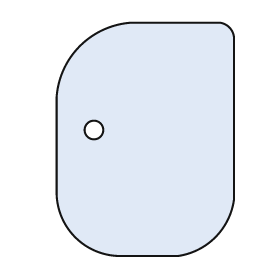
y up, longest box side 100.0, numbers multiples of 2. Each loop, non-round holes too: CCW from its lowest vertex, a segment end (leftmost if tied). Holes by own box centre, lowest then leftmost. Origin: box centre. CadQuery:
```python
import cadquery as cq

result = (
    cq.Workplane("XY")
    .moveTo(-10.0, -50.0)
    .lineTo(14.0, -50.0)
    .threePointArc((30.0, -42.0), (38.0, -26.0))
    .lineTo(38.0, 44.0)
    .threePointArc((36.0, 48.0), (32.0, 50.0))
    .lineTo(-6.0, 50.0)
    .threePointArc((-28.0, 40.0), (-38.0, 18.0))
    .lineTo(-38.0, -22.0)
    .threePointArc((-30.0, -42.0), (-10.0, -50.0))
    .close()
    .moveTo(-22.0, 4.0)
    .circle(4.0)
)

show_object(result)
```